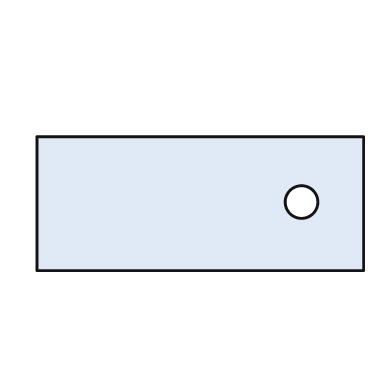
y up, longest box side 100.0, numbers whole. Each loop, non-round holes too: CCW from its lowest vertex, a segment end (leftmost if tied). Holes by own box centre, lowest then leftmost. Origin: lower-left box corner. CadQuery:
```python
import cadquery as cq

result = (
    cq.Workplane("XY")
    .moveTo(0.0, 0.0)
    .lineTo(100.0, 0.0)
    .lineTo(100.0, 41.0)
    .lineTo(0.0, 41.0)
    .close()
    .moveTo(81.0, 21.0)
    .circle(5.0)
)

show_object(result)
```